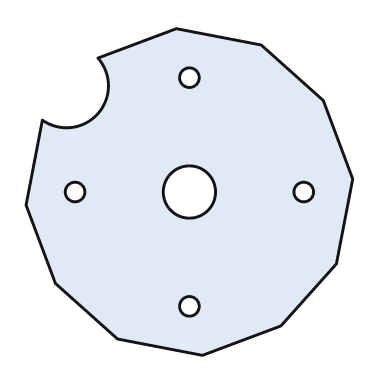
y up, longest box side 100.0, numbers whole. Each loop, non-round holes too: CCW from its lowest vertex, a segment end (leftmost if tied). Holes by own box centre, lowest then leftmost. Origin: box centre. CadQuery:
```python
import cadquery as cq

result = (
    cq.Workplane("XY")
    .moveTo(4.0, -50.0)
    .lineTo(28.0, -41.0)
    .lineTo(45.0, -22.0)
    .lineTo(50.0, 4.0)
    .lineTo(41.0, 28.0)
    .lineTo(22.0, 45.0)
    .lineTo(-4.0, 50.0)
    .lineTo(-28.0, 41.0)
    .threePointArc((-28.0, 24.0), (-45.0, 22.0))
    .lineTo(-50.0, -4.0)
    .lineTo(-41.0, -28.0)
    .lineTo(-22.0, -45.0)
    .close()
    .moveTo(0.0, -35.0)
    .circle(3.0)
    .moveTo(-35.0, 0.0)
    .circle(3.0)
    .moveTo(0.0, 0.0)
    .circle(8.0)
    .moveTo(35.0, 0.0)
    .circle(3.0)
    .moveTo(0.0, 35.0)
    .circle(3.0)
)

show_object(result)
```